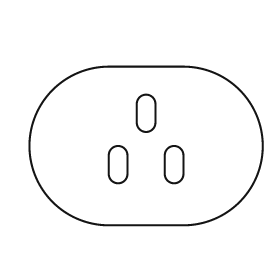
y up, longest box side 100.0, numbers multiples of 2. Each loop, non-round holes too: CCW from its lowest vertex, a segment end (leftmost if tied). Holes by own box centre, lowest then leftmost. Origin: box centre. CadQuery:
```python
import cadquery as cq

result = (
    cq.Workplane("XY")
    .moveTo(-16.0, -34.0)
    .lineTo(16.0, -34.0)
    .threePointArc((50.0, 0.0), (16.0, 34.0))
    .lineTo(-16.0, 34.0)
    .threePointArc((-50.0, 0.0), (-16.0, -34.0))
    .close()
    .moveTo(-16.0, -12.0)
    .threePointArc((-12.0, -16.0), (-8.0, -12.0))
    .lineTo(-8.0, -4.0)
    .threePointArc((-12.0, 0.0), (-16.0, -4.0))
    .close()
    .moveTo(8.0, -12.0)
    .threePointArc((12.0, -16.0), (16.0, -12.0))
    .lineTo(16.0, -4.0)
    .threePointArc((12.0, 0.0), (8.0, -4.0))
    .close()
    .moveTo(-4.0, 10.0)
    .threePointArc((0.0, 6.0), (4.0, 10.0))
    .lineTo(4.0, 18.0)
    .threePointArc((0.0, 22.0), (-4.0, 18.0))
    .close()
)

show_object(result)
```